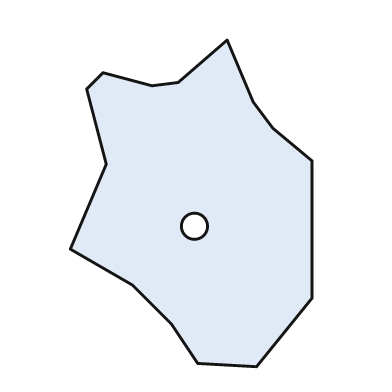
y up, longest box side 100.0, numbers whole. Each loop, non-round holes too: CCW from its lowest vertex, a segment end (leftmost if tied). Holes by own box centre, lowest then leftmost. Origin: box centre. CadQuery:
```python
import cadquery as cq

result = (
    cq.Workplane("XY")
    .moveTo(20.0, -50.0)
    .lineTo(37.0, -29.0)
    .lineTo(37.0, 13.0)
    .lineTo(25.0, 23.0)
    .lineTo(19.0, 31.0)
    .lineTo(11.0, 50.0)
    .lineTo(-4.0, 37.0)
    .lineTo(-12.0, 36.0)
    .lineTo(-27.0, 40.0)
    .lineTo(-32.0, 35.0)
    .lineTo(-26.0, 12.0)
    .lineTo(-37.0, -14.0)
    .lineTo(-18.0, -25.0)
    .lineTo(-6.0, -37.0)
    .lineTo(2.0, -49.0)
    .close()
    .moveTo(1.0, -7.0)
    .circle(4.0)
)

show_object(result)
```